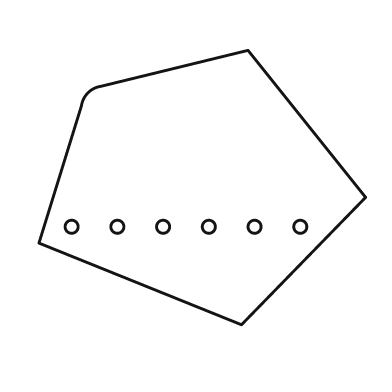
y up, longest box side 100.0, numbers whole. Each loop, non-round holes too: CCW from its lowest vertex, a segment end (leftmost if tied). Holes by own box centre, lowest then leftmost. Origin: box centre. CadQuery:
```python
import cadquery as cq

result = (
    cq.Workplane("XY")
    .moveTo(12.0, -42.0)
    .lineTo(50.0, -3.0)
    .lineTo(14.0, 42.0)
    .lineTo(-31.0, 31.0)
    .threePointArc((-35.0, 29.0), (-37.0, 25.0))
    .lineTo(-50.0, -17.0)
    .close()
    .moveTo(-40.0, -12.0)
    .circle(2.0)
    .moveTo(-26.0, -12.0)
    .circle(2.0)
    .moveTo(-12.0, -12.0)
    .circle(2.0)
    .moveTo(2.0, -12.0)
    .circle(2.0)
    .moveTo(16.0, -12.0)
    .circle(2.0)
    .moveTo(30.0, -12.0)
    .circle(2.0)
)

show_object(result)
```